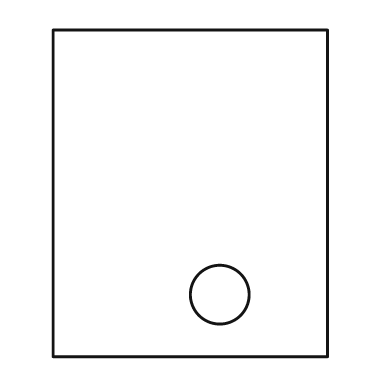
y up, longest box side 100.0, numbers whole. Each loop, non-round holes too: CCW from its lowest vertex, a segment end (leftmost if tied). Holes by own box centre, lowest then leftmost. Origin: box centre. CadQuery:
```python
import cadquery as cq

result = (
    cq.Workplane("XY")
    .moveTo(-42.0, -50.0)
    .lineTo(42.0, -50.0)
    .lineTo(42.0, 50.0)
    .lineTo(-42.0, 50.0)
    .close()
    .moveTo(9.0, -31.0)
    .circle(9.0)
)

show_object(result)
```